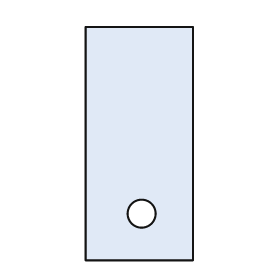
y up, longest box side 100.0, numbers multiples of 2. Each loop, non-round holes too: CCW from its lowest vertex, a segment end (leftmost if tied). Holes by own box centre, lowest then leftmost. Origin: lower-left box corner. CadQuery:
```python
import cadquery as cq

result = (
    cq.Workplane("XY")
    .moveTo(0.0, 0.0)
    .lineTo(46.0, 0.0)
    .lineTo(46.0, 100.0)
    .lineTo(0.0, 100.0)
    .close()
    .moveTo(24.0, 20.0)
    .circle(6.0)
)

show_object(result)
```